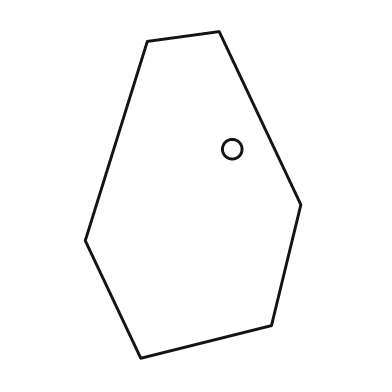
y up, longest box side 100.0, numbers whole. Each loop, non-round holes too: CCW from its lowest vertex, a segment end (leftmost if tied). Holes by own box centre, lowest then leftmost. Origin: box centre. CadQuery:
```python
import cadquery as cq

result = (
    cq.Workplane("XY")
    .moveTo(-16.0, -50.0)
    .lineTo(24.0, -40.0)
    .lineTo(33.0, -3.0)
    .lineTo(8.0, 50.0)
    .lineTo(-14.0, 47.0)
    .lineTo(-33.0, -14.0)
    .close()
    .moveTo(12.0, 14.0)
    .circle(3.0)
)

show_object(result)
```